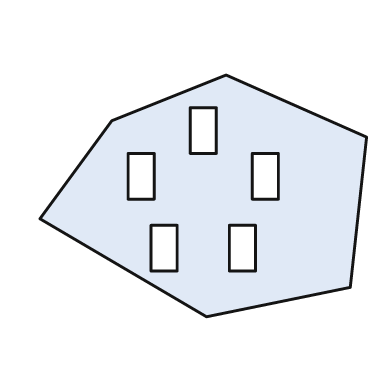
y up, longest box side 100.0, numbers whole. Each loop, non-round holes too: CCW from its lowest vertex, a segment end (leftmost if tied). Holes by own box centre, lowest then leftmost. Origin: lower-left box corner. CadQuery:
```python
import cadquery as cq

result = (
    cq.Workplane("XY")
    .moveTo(51.0, 0.0)
    .lineTo(95.0, 9.0)
    .lineTo(100.0, 55.0)
    .lineTo(57.0, 74.0)
    .lineTo(22.0, 60.0)
    .lineTo(0.0, 30.0)
    .close()
    .moveTo(34.0, 14.0)
    .lineTo(42.0, 14.0)
    .lineTo(42.0, 28.0)
    .lineTo(34.0, 28.0)
    .close()
    .moveTo(58.0, 14.0)
    .lineTo(66.0, 14.0)
    .lineTo(66.0, 28.0)
    .lineTo(58.0, 28.0)
    .close()
    .moveTo(27.0, 36.0)
    .lineTo(35.0, 36.0)
    .lineTo(35.0, 50.0)
    .lineTo(27.0, 50.0)
    .close()
    .moveTo(65.0, 36.0)
    .lineTo(73.0, 36.0)
    .lineTo(73.0, 50.0)
    .lineTo(65.0, 50.0)
    .close()
    .moveTo(46.0, 50.0)
    .lineTo(54.0, 50.0)
    .lineTo(54.0, 64.0)
    .lineTo(46.0, 64.0)
    .close()
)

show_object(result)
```